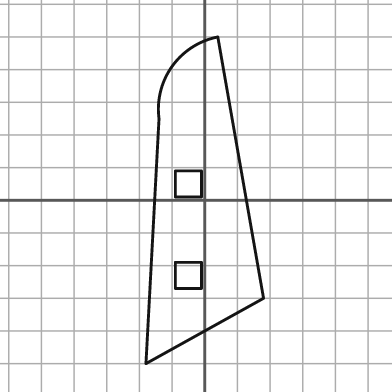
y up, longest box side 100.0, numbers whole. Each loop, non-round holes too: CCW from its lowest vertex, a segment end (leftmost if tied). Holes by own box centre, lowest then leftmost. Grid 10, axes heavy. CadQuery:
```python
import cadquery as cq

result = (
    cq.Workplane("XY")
    .moveTo(-18.0, -50.0)
    .lineTo(18.0, -30.0)
    .lineTo(4.0, 50.0)
    .threePointArc((-10.0, 41.0), (-14.0, 25.0))
    .close()
    .moveTo(-9.0, -27.0)
    .lineTo(-1.0, -27.0)
    .lineTo(-1.0, -19.0)
    .lineTo(-9.0, -19.0)
    .close()
    .moveTo(-9.0, 1.0)
    .lineTo(-1.0, 1.0)
    .lineTo(-1.0, 9.0)
    .lineTo(-9.0, 9.0)
    .close()
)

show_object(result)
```